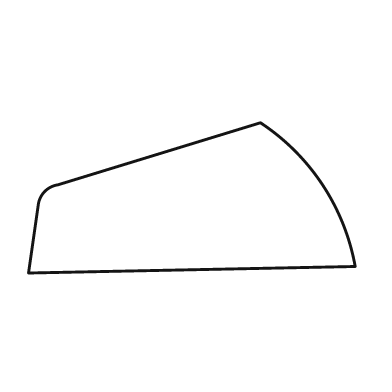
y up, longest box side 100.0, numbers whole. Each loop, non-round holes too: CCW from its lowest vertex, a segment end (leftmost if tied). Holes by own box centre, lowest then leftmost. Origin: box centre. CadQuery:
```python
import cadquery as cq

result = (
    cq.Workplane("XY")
    .moveTo(-50.0, -23.0)
    .lineTo(50.0, -21.0)
    .threePointArc((40.0, 4.0), (21.0, 23.0))
    .lineTo(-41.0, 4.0)
    .threePointArc((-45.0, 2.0), (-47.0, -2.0))
    .close()
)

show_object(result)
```